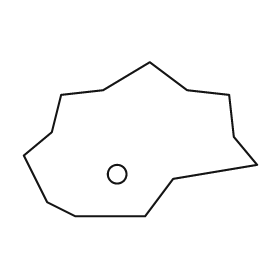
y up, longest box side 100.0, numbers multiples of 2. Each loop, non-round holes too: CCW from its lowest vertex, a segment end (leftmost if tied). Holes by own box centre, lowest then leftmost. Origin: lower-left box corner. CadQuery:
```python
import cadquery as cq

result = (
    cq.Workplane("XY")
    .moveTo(22.0, 0.0)
    .lineTo(52.0, 0.0)
    .lineTo(64.0, 16.0)
    .lineTo(100.0, 22.0)
    .lineTo(90.0, 34.0)
    .lineTo(88.0, 52.0)
    .lineTo(70.0, 54.0)
    .lineTo(54.0, 66.0)
    .lineTo(34.0, 54.0)
    .lineTo(16.0, 52.0)
    .lineTo(12.0, 36.0)
    .lineTo(0.0, 26.0)
    .lineTo(10.0, 6.0)
    .close()
    .moveTo(40.0, 18.0)
    .circle(4.0)
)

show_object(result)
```